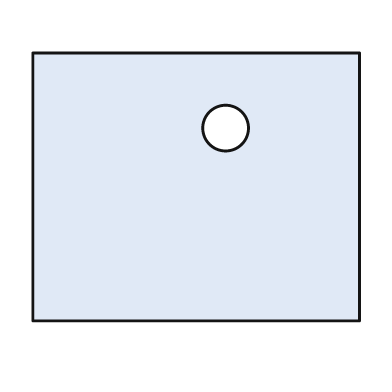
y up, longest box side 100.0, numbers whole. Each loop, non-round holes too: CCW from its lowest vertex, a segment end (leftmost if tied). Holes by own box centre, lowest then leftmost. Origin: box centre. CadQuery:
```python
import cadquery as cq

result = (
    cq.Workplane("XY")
    .moveTo(-50.0, -41.0)
    .lineTo(50.0, -41.0)
    .lineTo(50.0, 41.0)
    .lineTo(-50.0, 41.0)
    .close()
    .moveTo(9.0, 18.0)
    .circle(7.0)
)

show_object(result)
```